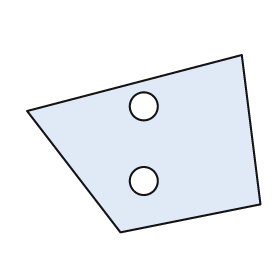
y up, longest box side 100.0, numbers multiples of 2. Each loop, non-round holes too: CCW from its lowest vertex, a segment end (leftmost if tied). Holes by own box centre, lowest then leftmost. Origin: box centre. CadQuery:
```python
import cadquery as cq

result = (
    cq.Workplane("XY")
    .moveTo(-10.0, -38.0)
    .lineTo(50.0, -26.0)
    .lineTo(42.0, 38.0)
    .lineTo(-50.0, 14.0)
    .close()
    .moveTo(0.0, -16.0)
    .circle(6.0)
    .moveTo(0.0, 16.0)
    .circle(6.0)
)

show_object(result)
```